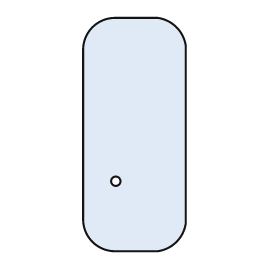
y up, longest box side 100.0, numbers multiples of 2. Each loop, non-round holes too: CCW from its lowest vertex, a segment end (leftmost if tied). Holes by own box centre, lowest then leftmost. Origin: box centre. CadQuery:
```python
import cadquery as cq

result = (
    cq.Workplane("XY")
    .moveTo(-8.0, -50.0)
    .lineTo(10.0, -50.0)
    .threePointArc((18.0, -46.0), (22.0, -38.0))
    .lineTo(22.0, 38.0)
    .threePointArc((18.0, 46.0), (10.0, 50.0))
    .lineTo(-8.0, 50.0)
    .threePointArc((-18.0, 46.0), (-22.0, 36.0))
    .lineTo(-22.0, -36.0)
    .threePointArc((-18.0, -46.0), (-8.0, -50.0))
    .close()
    .moveTo(-8.0, -20.0)
    .circle(2.0)
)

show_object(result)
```